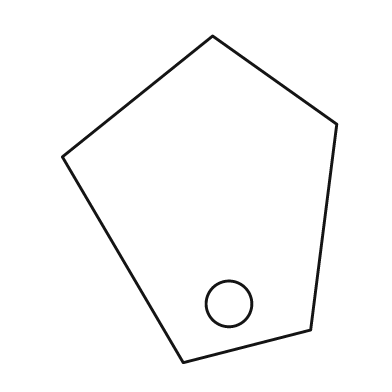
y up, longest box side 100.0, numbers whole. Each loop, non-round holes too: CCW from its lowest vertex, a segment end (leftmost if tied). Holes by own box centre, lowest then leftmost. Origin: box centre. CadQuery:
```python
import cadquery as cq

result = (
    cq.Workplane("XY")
    .moveTo(-5.0, -50.0)
    .lineTo(34.0, -40.0)
    .lineTo(42.0, 23.0)
    .lineTo(4.0, 50.0)
    .lineTo(-42.0, 13.0)
    .close()
    .moveTo(9.0, -32.0)
    .circle(7.0)
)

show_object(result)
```